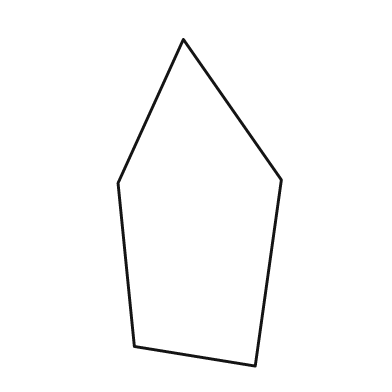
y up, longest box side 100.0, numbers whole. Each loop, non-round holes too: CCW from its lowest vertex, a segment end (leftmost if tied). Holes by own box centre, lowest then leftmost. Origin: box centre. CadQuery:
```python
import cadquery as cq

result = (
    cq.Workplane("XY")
    .moveTo(17.0, -50.0)
    .lineTo(25.0, 7.0)
    .lineTo(-5.0, 50.0)
    .lineTo(-25.0, 6.0)
    .lineTo(-20.0, -44.0)
    .close()
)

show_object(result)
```